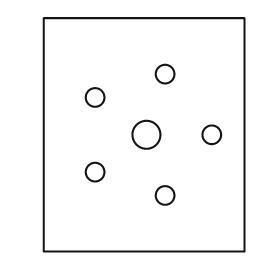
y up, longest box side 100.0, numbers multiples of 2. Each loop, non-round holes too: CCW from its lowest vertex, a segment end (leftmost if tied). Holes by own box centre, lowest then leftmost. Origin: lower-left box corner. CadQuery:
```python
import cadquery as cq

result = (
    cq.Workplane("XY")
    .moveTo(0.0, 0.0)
    .lineTo(86.0, 0.0)
    .lineTo(86.0, 100.0)
    .lineTo(0.0, 100.0)
    .close()
    .moveTo(52.0, 24.0)
    .circle(4.0)
    .moveTo(22.0, 34.0)
    .circle(4.0)
    .moveTo(44.0, 50.0)
    .circle(6.0)
    .moveTo(72.0, 50.0)
    .circle(4.0)
    .moveTo(22.0, 66.0)
    .circle(4.0)
    .moveTo(52.0, 76.0)
    .circle(4.0)
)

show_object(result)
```